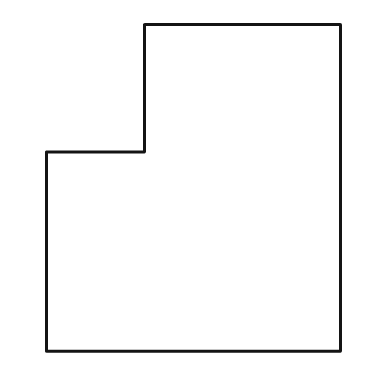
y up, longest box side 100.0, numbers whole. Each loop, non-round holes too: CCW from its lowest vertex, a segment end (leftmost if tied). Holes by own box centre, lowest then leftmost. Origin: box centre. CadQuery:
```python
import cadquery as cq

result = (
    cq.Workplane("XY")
    .moveTo(-45.0, -50.0)
    .lineTo(45.0, -50.0)
    .lineTo(45.0, 50.0)
    .lineTo(-15.0, 50.0)
    .lineTo(-15.0, 11.0)
    .lineTo(-45.0, 11.0)
    .close()
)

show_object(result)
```